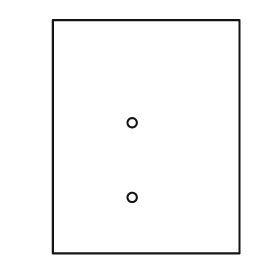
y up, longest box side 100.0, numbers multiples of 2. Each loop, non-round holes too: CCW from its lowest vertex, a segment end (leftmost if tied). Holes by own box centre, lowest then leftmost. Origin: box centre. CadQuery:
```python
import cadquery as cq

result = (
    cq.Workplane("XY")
    .moveTo(-40.0, -50.0)
    .lineTo(40.0, -50.0)
    .lineTo(40.0, 50.0)
    .lineTo(-40.0, 50.0)
    .close()
    .moveTo(-6.0, -26.0)
    .circle(2.0)
    .moveTo(-6.0, 6.0)
    .circle(2.0)
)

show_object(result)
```